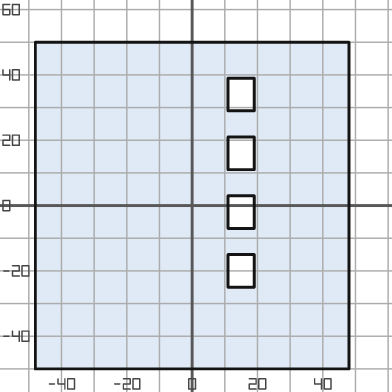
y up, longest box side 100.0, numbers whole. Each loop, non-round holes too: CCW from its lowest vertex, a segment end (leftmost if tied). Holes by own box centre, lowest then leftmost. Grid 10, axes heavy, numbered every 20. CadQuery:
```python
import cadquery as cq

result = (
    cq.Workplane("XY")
    .moveTo(-48.0, -50.0)
    .lineTo(48.0, -50.0)
    .lineTo(48.0, 50.0)
    .lineTo(-48.0, 50.0)
    .close()
    .moveTo(11.0, -25.0)
    .lineTo(19.0, -25.0)
    .lineTo(19.0, -15.0)
    .lineTo(11.0, -15.0)
    .close()
    .moveTo(11.0, -7.0)
    .lineTo(19.0, -7.0)
    .lineTo(19.0, 3.0)
    .lineTo(11.0, 3.0)
    .close()
    .moveTo(11.0, 11.0)
    .lineTo(19.0, 11.0)
    .lineTo(19.0, 21.0)
    .lineTo(11.0, 21.0)
    .close()
    .moveTo(11.0, 29.0)
    .lineTo(19.0, 29.0)
    .lineTo(19.0, 39.0)
    .lineTo(11.0, 39.0)
    .close()
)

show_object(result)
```